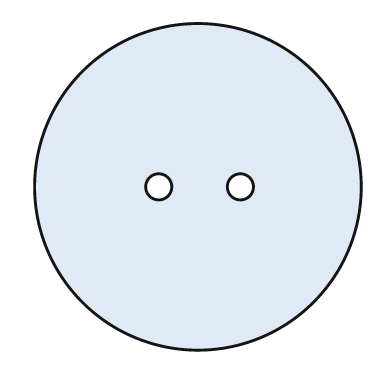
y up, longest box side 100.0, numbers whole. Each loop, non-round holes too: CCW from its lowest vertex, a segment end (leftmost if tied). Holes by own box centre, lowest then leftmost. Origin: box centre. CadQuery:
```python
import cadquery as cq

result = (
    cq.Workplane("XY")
    .moveTo(0.0, 0.0)
    .circle(50.0)
    .moveTo(-12.0, 0.0)
    .circle(4.0)
    .moveTo(13.0, 0.0)
    .circle(4.0)
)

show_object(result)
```